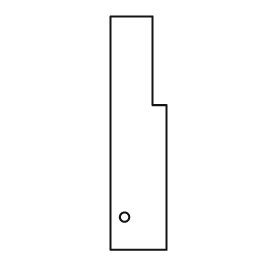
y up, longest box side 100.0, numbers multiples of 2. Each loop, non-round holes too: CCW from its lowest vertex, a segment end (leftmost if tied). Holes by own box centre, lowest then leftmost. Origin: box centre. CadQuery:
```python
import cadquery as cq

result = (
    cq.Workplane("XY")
    .moveTo(-12.0, -50.0)
    .lineTo(12.0, -50.0)
    .lineTo(12.0, 12.0)
    .lineTo(6.0, 12.0)
    .lineTo(6.0, 50.0)
    .lineTo(-12.0, 50.0)
    .close()
    .moveTo(-6.0, -36.0)
    .circle(2.0)
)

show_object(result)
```